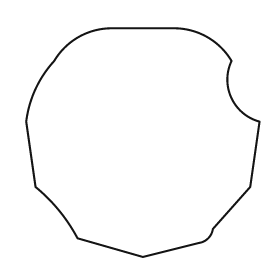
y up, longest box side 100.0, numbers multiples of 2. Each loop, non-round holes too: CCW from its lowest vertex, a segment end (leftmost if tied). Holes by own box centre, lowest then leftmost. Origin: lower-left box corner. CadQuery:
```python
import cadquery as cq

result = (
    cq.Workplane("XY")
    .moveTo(50.0, 0.0)
    .lineTo(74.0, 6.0)
    .threePointArc((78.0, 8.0), (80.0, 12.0))
    .lineTo(96.0, 30.0)
    .lineTo(100.0, 58.0)
    .threePointArc((88.0, 68.0), (88.0, 84.0))
    .threePointArc((78.0, 94.0), (64.0, 98.0))
    .lineTo(36.0, 98.0)
    .threePointArc((22.0, 94.0), (12.0, 84.0))
    .threePointArc((4.0, 72.0), (0.0, 58.0))
    .lineTo(4.0, 30.0)
    .threePointArc((14.0, 20.0), (22.0, 8.0))
    .close()
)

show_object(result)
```